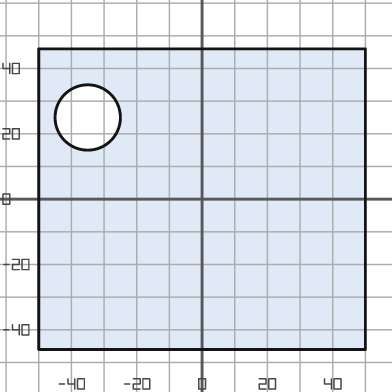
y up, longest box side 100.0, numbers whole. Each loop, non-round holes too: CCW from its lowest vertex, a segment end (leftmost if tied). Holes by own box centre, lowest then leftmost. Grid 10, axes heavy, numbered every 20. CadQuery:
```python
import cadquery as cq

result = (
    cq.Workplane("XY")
    .moveTo(-50.0, -46.0)
    .lineTo(50.0, -46.0)
    .lineTo(50.0, 46.0)
    .lineTo(-50.0, 46.0)
    .close()
    .moveTo(-35.0, 25.0)
    .circle(10.0)
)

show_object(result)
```